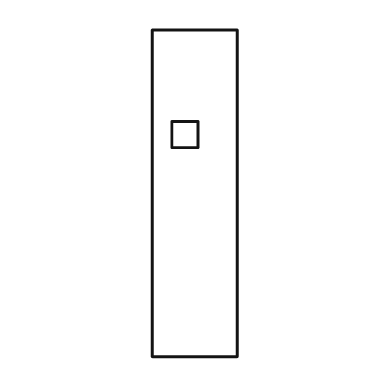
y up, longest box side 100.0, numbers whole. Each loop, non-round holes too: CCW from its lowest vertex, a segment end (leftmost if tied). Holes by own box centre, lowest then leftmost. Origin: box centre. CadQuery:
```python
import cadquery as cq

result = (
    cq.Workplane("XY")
    .moveTo(-13.0, -50.0)
    .lineTo(13.0, -50.0)
    .lineTo(13.0, 50.0)
    .lineTo(-13.0, 50.0)
    .close()
    .moveTo(-7.0, 14.0)
    .lineTo(1.0, 14.0)
    .lineTo(1.0, 22.0)
    .lineTo(-7.0, 22.0)
    .close()
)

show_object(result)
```